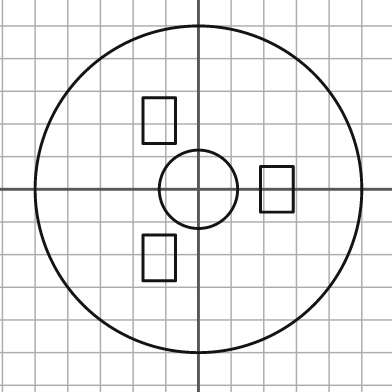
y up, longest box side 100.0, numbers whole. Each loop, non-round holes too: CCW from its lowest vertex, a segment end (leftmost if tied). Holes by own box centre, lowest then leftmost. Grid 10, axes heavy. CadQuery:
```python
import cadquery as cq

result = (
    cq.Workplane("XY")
    .moveTo(0.0, 0.0)
    .circle(50.0)
    .moveTo(-17.0, -28.0)
    .lineTo(-7.0, -28.0)
    .lineTo(-7.0, -14.0)
    .lineTo(-17.0, -14.0)
    .close()
    .moveTo(0.0, 0.0)
    .circle(12.0)
    .moveTo(19.0, -7.0)
    .lineTo(29.0, -7.0)
    .lineTo(29.0, 7.0)
    .lineTo(19.0, 7.0)
    .close()
    .moveTo(-17.0, 14.0)
    .lineTo(-7.0, 14.0)
    .lineTo(-7.0, 28.0)
    .lineTo(-17.0, 28.0)
    .close()
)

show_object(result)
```